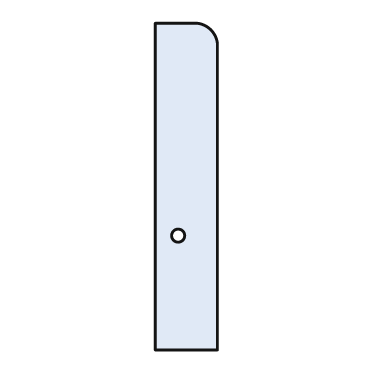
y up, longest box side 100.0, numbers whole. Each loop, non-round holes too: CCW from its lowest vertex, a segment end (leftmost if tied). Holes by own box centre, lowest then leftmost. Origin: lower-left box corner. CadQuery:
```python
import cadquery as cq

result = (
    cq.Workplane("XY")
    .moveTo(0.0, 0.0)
    .lineTo(19.0, 0.0)
    .lineTo(19.0, 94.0)
    .threePointArc((17.0, 98.0), (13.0, 100.0))
    .lineTo(0.0, 100.0)
    .close()
    .moveTo(7.0, 35.0)
    .circle(2.0)
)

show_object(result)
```